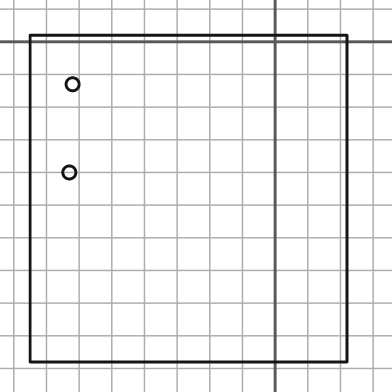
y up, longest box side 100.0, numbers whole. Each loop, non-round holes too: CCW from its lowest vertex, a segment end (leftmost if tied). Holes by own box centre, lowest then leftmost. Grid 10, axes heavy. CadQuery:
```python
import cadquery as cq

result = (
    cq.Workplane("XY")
    .moveTo(-75.0, -98.0)
    .lineTo(22.0, -98.0)
    .lineTo(22.0, 2.0)
    .lineTo(-75.0, 2.0)
    .close()
    .moveTo(-63.0, -40.0)
    .circle(2.0)
    .moveTo(-62.0, -13.0)
    .circle(2.0)
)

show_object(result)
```